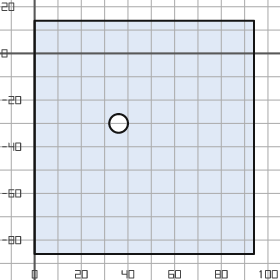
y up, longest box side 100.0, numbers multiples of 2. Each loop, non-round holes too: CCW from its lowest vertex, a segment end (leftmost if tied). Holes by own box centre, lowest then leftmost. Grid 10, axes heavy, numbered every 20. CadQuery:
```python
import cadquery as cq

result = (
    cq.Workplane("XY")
    .moveTo(0.0, -86.0)
    .lineTo(94.0, -86.0)
    .lineTo(94.0, 14.0)
    .lineTo(0.0, 14.0)
    .close()
    .moveTo(36.0, -30.0)
    .circle(4.0)
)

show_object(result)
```